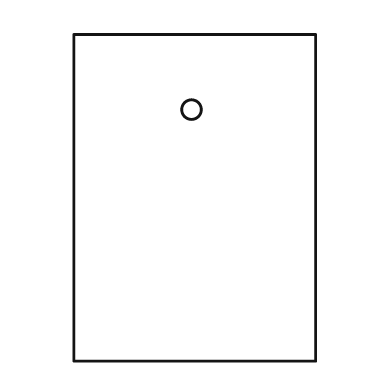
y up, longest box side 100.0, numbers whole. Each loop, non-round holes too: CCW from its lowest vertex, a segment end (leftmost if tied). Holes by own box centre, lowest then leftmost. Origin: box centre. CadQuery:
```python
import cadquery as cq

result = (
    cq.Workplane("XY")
    .moveTo(-37.0, -50.0)
    .lineTo(37.0, -50.0)
    .lineTo(37.0, 50.0)
    .lineTo(-37.0, 50.0)
    .close()
    .moveTo(-1.0, 27.0)
    .circle(3.0)
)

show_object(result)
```